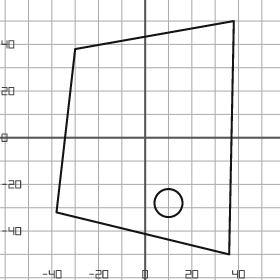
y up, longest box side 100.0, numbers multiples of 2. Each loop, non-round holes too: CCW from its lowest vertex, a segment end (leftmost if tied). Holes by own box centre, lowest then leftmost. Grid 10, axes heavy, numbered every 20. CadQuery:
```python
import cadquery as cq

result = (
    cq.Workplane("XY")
    .moveTo(36.0, -50.0)
    .lineTo(38.0, 50.0)
    .lineTo(-30.0, 38.0)
    .lineTo(-38.0, -32.0)
    .close()
    .moveTo(10.0, -28.0)
    .circle(6.0)
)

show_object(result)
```